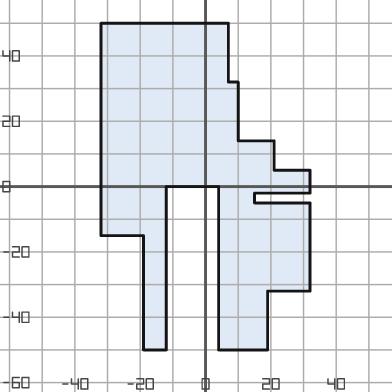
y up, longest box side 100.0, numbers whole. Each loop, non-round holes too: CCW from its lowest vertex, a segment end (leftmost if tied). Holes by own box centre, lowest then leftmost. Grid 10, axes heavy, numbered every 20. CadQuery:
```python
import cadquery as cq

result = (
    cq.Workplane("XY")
    .moveTo(-19.0, -50.0)
    .lineTo(-12.0, -50.0)
    .lineTo(-12.0, 0.0)
    .lineTo(4.0, 0.0)
    .lineTo(4.0, -50.0)
    .lineTo(19.0, -50.0)
    .lineTo(19.0, -32.0)
    .lineTo(32.0, -32.0)
    .lineTo(32.0, -5.0)
    .lineTo(15.0, -5.0)
    .lineTo(15.0, -2.0)
    .lineTo(32.0, -2.0)
    .lineTo(32.0, 5.0)
    .lineTo(21.0, 5.0)
    .lineTo(21.0, 14.0)
    .lineTo(10.0, 14.0)
    .lineTo(10.0, 32.0)
    .lineTo(7.0, 32.0)
    .lineTo(7.0, 50.0)
    .lineTo(-32.0, 50.0)
    .lineTo(-32.0, -15.0)
    .lineTo(-19.0, -15.0)
    .close()
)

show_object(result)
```